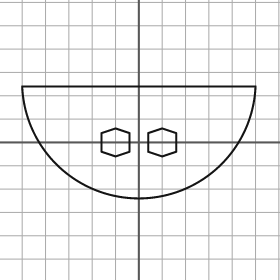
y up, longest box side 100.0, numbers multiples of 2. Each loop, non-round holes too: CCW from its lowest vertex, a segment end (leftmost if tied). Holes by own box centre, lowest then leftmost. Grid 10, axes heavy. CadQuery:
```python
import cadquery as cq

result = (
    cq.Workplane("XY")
    .moveTo(-50.0, 24.0)
    .threePointArc((0.0, -24.0), (50.0, 24.0))
    .close()
    .moveTo(-10.0, -6.0)
    .lineTo(-4.0, -4.0)
    .lineTo(-4.0, 4.0)
    .lineTo(-10.0, 6.0)
    .lineTo(-16.0, 4.0)
    .lineTo(-16.0, -4.0)
    .close()
    .moveTo(10.0, -6.0)
    .lineTo(16.0, -4.0)
    .lineTo(16.0, 4.0)
    .lineTo(10.0, 6.0)
    .lineTo(4.0, 4.0)
    .lineTo(4.0, -4.0)
    .close()
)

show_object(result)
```